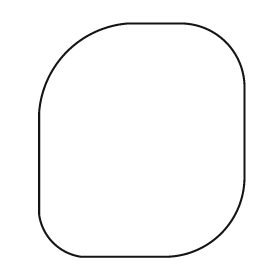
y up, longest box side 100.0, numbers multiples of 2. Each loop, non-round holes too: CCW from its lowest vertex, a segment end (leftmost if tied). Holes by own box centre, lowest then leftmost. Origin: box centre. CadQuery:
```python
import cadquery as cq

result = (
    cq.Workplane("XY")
    .moveTo(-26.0, -50.0)
    .lineTo(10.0, -50.0)
    .threePointArc((34.0, -40.0), (44.0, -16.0))
    .lineTo(44.0, 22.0)
    .threePointArc((36.0, 42.0), (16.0, 50.0))
    .lineTo(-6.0, 50.0)
    .threePointArc((-32.0, 38.0), (-44.0, 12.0))
    .lineTo(-44.0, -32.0)
    .threePointArc((-38.0, -44.0), (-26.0, -50.0))
    .close()
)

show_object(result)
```